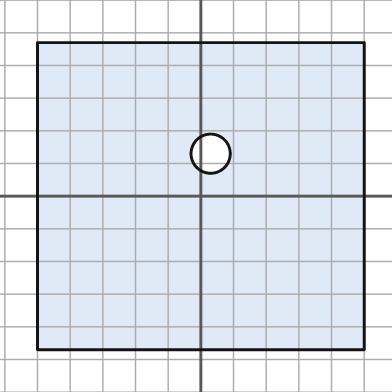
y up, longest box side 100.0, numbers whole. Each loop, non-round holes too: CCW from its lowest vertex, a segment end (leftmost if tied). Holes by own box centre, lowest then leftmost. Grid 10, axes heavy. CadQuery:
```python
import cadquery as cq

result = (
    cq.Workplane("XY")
    .moveTo(-50.0, -47.0)
    .lineTo(50.0, -47.0)
    .lineTo(50.0, 47.0)
    .lineTo(-50.0, 47.0)
    .close()
    .moveTo(3.0, 13.0)
    .circle(6.0)
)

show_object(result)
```